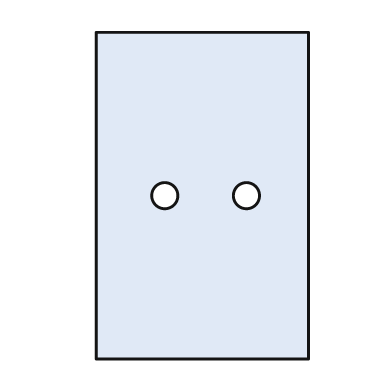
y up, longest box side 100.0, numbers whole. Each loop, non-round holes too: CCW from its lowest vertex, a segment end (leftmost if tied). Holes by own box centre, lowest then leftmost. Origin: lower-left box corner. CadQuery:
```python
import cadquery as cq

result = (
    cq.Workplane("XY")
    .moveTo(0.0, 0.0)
    .lineTo(65.0, 0.0)
    .lineTo(65.0, 100.0)
    .lineTo(0.0, 100.0)
    .close()
    .moveTo(21.0, 50.0)
    .circle(4.0)
    .moveTo(46.0, 50.0)
    .circle(4.0)
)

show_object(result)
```